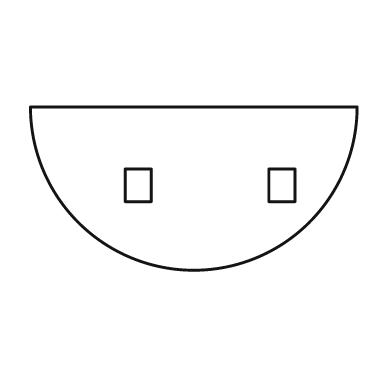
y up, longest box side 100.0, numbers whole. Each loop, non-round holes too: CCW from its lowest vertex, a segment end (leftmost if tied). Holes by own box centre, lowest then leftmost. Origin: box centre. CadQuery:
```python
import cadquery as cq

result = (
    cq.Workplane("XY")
    .moveTo(-50.0, 25.0)
    .threePointArc((0.0, -25.0), (50.0, 25.0))
    .close()
    .moveTo(-21.0, -4.0)
    .lineTo(-13.0, -4.0)
    .lineTo(-13.0, 6.0)
    .lineTo(-21.0, 6.0)
    .close()
    .moveTo(23.0, -4.0)
    .lineTo(31.0, -4.0)
    .lineTo(31.0, 6.0)
    .lineTo(23.0, 6.0)
    .close()
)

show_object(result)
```